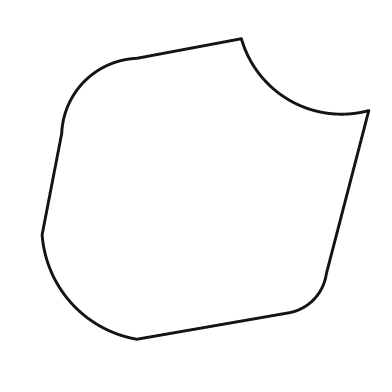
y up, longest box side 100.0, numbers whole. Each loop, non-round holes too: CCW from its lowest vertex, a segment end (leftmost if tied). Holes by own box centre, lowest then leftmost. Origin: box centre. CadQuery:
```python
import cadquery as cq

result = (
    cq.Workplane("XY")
    .moveTo(-21.0, -46.0)
    .lineTo(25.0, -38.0)
    .threePointArc((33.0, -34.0), (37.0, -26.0))
    .lineTo(50.0, 24.0)
    .threePointArc((26.0, 27.0), (11.0, 46.0))
    .lineTo(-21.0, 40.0)
    .threePointArc((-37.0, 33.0), (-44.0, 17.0))
    .lineTo(-50.0, -14.0)
    .threePointArc((-41.0, -35.0), (-21.0, -46.0))
    .close()
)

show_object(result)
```